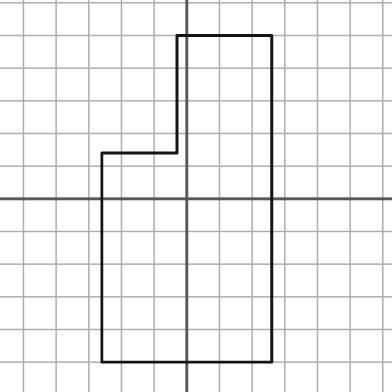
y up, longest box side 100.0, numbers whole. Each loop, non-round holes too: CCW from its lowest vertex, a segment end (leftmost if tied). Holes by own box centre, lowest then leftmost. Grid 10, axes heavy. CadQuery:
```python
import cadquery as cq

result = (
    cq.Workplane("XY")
    .moveTo(-26.0, -50.0)
    .lineTo(26.0, -50.0)
    .lineTo(26.0, 50.0)
    .lineTo(-3.0, 50.0)
    .lineTo(-3.0, 14.0)
    .lineTo(-26.0, 14.0)
    .close()
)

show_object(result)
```